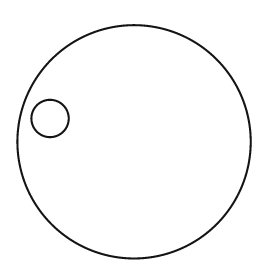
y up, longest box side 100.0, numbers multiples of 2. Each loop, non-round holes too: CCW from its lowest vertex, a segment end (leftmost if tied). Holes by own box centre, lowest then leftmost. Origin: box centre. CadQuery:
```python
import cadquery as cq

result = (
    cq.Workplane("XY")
    .moveTo(0.0, 0.0)
    .circle(50.0)
    .moveTo(-36.0, 10.0)
    .circle(8.0)
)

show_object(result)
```